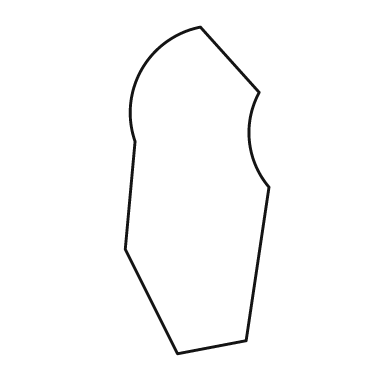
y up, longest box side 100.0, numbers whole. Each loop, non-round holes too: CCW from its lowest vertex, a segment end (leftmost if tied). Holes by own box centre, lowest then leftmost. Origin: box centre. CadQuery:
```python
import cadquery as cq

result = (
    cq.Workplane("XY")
    .moveTo(-6.0, -50.0)
    .lineTo(15.0, -46.0)
    .lineTo(22.0, 1.0)
    .threePointArc((16.0, 15.0), (19.0, 30.0))
    .lineTo(1.0, 50.0)
    .threePointArc((-17.0, 37.0), (-19.0, 15.0))
    .lineTo(-22.0, -18.0)
    .close()
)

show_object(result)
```